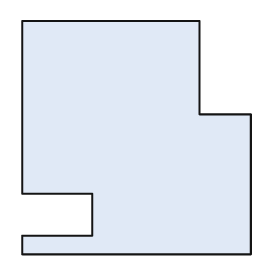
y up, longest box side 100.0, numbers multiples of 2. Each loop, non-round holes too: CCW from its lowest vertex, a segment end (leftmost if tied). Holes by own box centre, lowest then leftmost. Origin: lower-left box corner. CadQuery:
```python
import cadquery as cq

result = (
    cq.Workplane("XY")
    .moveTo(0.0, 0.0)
    .lineTo(98.0, 0.0)
    .lineTo(98.0, 60.0)
    .lineTo(76.0, 60.0)
    .lineTo(76.0, 100.0)
    .lineTo(0.0, 100.0)
    .lineTo(0.0, 26.0)
    .lineTo(30.0, 26.0)
    .lineTo(30.0, 8.0)
    .lineTo(0.0, 8.0)
    .close()
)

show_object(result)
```